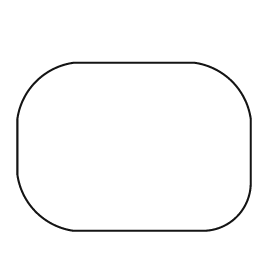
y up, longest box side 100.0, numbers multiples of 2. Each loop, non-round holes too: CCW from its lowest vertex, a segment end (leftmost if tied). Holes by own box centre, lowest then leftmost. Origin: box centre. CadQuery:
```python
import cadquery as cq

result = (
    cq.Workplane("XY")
    .moveTo(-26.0, -36.0)
    .lineTo(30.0, -36.0)
    .threePointArc((44.0, -30.0), (50.0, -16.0))
    .lineTo(50.0, 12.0)
    .threePointArc((42.0, 28.0), (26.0, 36.0))
    .lineTo(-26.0, 36.0)
    .threePointArc((-42.0, 28.0), (-50.0, 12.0))
    .lineTo(-50.0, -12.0)
    .threePointArc((-42.0, -28.0), (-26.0, -36.0))
    .close()
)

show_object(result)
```